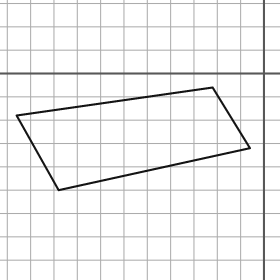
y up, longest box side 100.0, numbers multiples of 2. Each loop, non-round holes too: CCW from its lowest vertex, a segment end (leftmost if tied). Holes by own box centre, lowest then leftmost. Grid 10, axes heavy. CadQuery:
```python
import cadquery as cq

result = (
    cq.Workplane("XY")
    .moveTo(-88.0, -50.0)
    .lineTo(-6.0, -32.0)
    .lineTo(-22.0, -6.0)
    .lineTo(-106.0, -18.0)
    .close()
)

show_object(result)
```